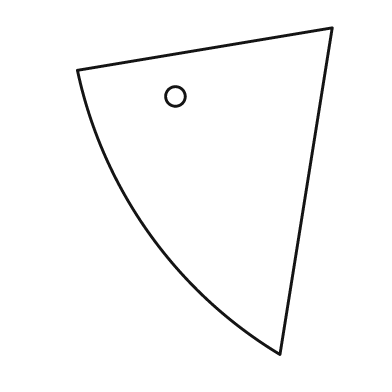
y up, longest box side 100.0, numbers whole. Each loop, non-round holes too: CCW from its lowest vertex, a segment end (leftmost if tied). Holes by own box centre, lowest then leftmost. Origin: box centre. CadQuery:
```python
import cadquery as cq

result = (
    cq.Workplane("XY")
    .moveTo(23.0, -50.0)
    .lineTo(39.0, 50.0)
    .lineTo(-39.0, 37.0)
    .threePointArc((-17.0, -13.0), (23.0, -50.0))
    .close()
    .moveTo(-9.0, 29.0)
    .circle(3.0)
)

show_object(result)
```